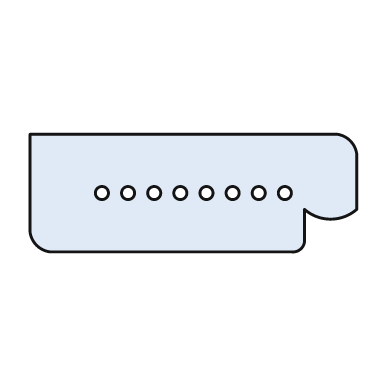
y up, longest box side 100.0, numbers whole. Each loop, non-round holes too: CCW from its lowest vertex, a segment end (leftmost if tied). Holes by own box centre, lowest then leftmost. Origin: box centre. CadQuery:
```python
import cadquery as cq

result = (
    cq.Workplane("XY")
    .moveTo(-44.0, -18.0)
    .lineTo(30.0, -18.0)
    .threePointArc((33.0, -17.0), (34.0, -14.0))
    .lineTo(34.0, -5.0)
    .threePointArc((42.0, -8.0), (50.0, -5.0))
    .lineTo(50.0, 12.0)
    .threePointArc((48.0, 16.0), (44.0, 18.0))
    .lineTo(-50.0, 18.0)
    .lineTo(-50.0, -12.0)
    .threePointArc((-48.0, -16.0), (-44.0, -18.0))
    .close()
    .moveTo(-28.0, 0.0)
    .circle(2.0)
    .moveTo(-20.0, 0.0)
    .circle(2.0)
    .moveTo(-12.0, 0.0)
    .circle(2.0)
    .moveTo(-4.0, 0.0)
    .circle(2.0)
    .moveTo(4.0, 0.0)
    .circle(2.0)
    .moveTo(12.0, 0.0)
    .circle(2.0)
    .moveTo(20.0, 0.0)
    .circle(2.0)
    .moveTo(28.0, 0.0)
    .circle(2.0)
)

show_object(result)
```